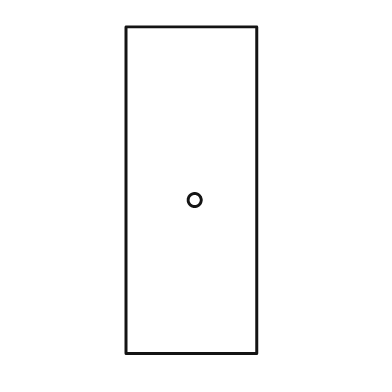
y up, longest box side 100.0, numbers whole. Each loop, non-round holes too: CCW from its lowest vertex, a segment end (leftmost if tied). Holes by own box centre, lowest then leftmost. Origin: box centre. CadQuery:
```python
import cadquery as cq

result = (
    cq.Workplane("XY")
    .moveTo(-20.0, -50.0)
    .lineTo(20.0, -50.0)
    .lineTo(20.0, 50.0)
    .lineTo(-20.0, 50.0)
    .close()
    .moveTo(1.0, -3.0)
    .circle(2.0)
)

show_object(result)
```